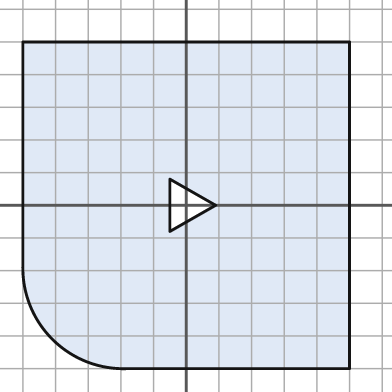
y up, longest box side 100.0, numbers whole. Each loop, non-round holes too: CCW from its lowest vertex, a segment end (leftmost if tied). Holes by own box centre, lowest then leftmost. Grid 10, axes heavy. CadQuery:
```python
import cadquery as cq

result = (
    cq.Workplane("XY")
    .moveTo(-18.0, -50.0)
    .lineTo(50.0, -50.0)
    .lineTo(50.0, 50.0)
    .lineTo(-50.0, 50.0)
    .lineTo(-50.0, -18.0)
    .threePointArc((-41.0, -41.0), (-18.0, -50.0))
    .close()
    .moveTo(-5.0, -8.0)
    .lineTo(9.0, 0.0)
    .lineTo(-5.0, 8.0)
    .close()
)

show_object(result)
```